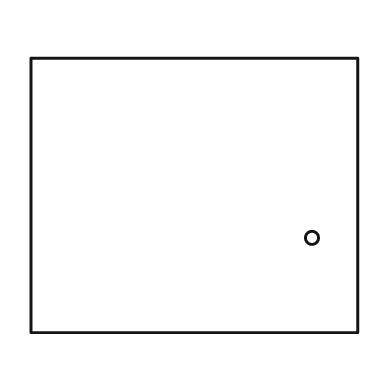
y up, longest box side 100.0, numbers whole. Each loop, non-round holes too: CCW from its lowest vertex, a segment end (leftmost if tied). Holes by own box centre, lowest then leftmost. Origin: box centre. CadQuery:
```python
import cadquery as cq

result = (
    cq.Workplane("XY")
    .moveTo(-50.0, -42.0)
    .lineTo(50.0, -42.0)
    .lineTo(50.0, 42.0)
    .lineTo(-50.0, 42.0)
    .close()
    .moveTo(36.0, -13.0)
    .circle(2.0)
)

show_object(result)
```